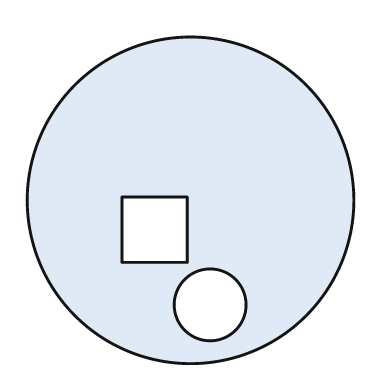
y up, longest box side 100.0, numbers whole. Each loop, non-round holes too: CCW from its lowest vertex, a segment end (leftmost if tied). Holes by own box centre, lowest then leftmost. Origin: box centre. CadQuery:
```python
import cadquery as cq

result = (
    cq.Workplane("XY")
    .moveTo(0.0, 0.0)
    .circle(50.0)
    .moveTo(6.0, -32.0)
    .circle(11.0)
    .moveTo(-21.0, -19.0)
    .lineTo(-1.0, -19.0)
    .lineTo(-1.0, 1.0)
    .lineTo(-21.0, 1.0)
    .close()
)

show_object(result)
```